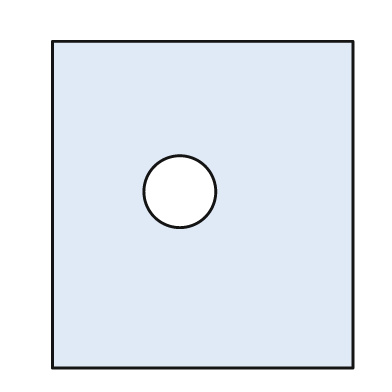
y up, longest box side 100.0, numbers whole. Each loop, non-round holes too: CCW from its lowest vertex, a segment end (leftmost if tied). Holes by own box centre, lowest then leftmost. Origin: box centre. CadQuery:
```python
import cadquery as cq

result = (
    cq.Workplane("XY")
    .moveTo(-46.0, -50.0)
    .lineTo(46.0, -50.0)
    .lineTo(46.0, 50.0)
    .lineTo(-46.0, 50.0)
    .close()
    .moveTo(-7.0, 4.0)
    .circle(11.0)
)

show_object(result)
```